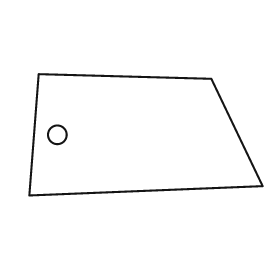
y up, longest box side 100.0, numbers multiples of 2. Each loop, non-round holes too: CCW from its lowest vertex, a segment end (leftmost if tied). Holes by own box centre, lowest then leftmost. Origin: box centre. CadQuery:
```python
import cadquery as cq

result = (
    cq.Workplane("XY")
    .moveTo(-50.0, -26.0)
    .lineTo(50.0, -22.0)
    .lineTo(28.0, 24.0)
    .lineTo(-46.0, 26.0)
    .close()
    .moveTo(-38.0, 0.0)
    .circle(4.0)
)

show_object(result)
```